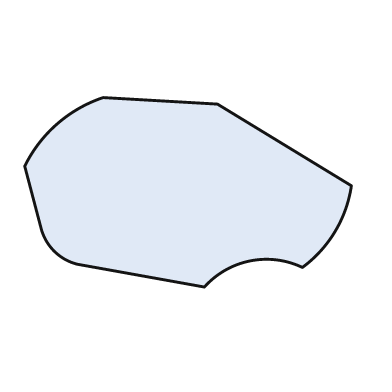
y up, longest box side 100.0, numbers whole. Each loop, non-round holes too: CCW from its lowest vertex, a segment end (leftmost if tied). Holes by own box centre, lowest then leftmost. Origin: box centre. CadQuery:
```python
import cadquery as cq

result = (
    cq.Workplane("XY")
    .moveTo(5.0, -29.0)
    .threePointArc((19.0, -21.0), (35.0, -23.0))
    .threePointArc((45.0, -12.0), (50.0, 2.0))
    .lineTo(9.0, 27.0)
    .lineTo(-26.0, 29.0)
    .threePointArc((-40.0, 21.0), (-50.0, 8.0))
    .lineTo(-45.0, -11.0)
    .threePointArc((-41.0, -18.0), (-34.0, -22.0))
    .close()
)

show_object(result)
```